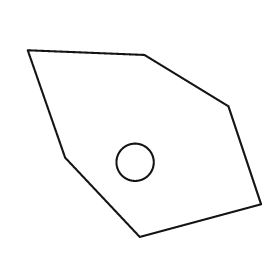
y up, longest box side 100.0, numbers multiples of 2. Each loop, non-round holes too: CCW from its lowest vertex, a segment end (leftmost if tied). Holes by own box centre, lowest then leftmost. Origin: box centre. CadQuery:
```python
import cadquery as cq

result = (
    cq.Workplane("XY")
    .moveTo(-2.0, -40.0)
    .lineTo(50.0, -26.0)
    .lineTo(36.0, 16.0)
    .lineTo(0.0, 38.0)
    .lineTo(-50.0, 40.0)
    .lineTo(-34.0, -6.0)
    .close()
    .moveTo(-4.0, -8.0)
    .circle(8.0)
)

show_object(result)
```